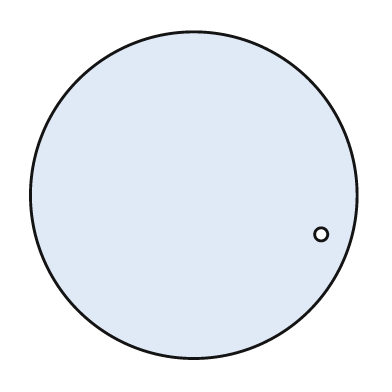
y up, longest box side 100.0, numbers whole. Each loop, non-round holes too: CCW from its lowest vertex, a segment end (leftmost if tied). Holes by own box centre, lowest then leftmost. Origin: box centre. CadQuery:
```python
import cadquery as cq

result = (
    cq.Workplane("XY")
    .moveTo(0.0, 0.0)
    .circle(50.0)
    .moveTo(39.0, -12.0)
    .circle(2.0)
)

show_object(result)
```